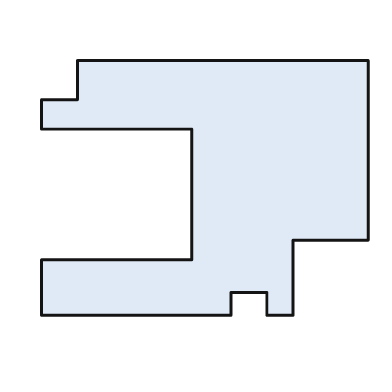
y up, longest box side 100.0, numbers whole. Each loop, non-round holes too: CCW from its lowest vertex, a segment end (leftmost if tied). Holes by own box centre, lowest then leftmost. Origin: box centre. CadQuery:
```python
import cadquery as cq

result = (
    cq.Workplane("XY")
    .moveTo(-50.0, -39.0)
    .lineTo(8.0, -39.0)
    .lineTo(8.0, -32.0)
    .lineTo(19.0, -32.0)
    .lineTo(19.0, -39.0)
    .lineTo(27.0, -39.0)
    .lineTo(27.0, -16.0)
    .lineTo(50.0, -16.0)
    .lineTo(50.0, 39.0)
    .lineTo(-39.0, 39.0)
    .lineTo(-39.0, 27.0)
    .lineTo(-50.0, 27.0)
    .lineTo(-50.0, 18.0)
    .lineTo(-4.0, 18.0)
    .lineTo(-4.0, -22.0)
    .lineTo(-50.0, -22.0)
    .close()
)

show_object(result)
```